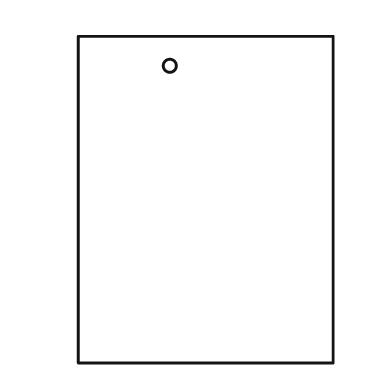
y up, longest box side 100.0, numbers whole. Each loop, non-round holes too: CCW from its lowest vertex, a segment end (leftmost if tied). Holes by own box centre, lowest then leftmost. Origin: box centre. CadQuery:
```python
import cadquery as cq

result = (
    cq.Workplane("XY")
    .moveTo(-39.0, -50.0)
    .lineTo(39.0, -50.0)
    .lineTo(39.0, 50.0)
    .lineTo(-39.0, 50.0)
    .close()
    .moveTo(-11.0, 41.0)
    .circle(2.0)
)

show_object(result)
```